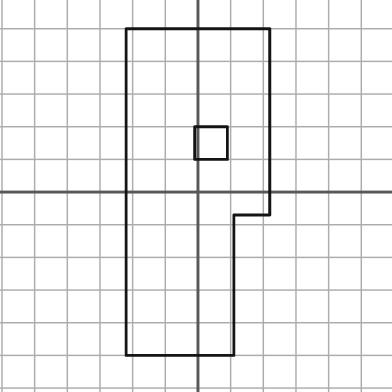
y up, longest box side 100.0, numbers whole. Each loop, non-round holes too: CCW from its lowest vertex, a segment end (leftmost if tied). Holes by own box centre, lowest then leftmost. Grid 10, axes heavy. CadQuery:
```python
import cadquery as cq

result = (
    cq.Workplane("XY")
    .moveTo(-22.0, -50.0)
    .lineTo(11.0, -50.0)
    .lineTo(11.0, -7.0)
    .lineTo(22.0, -7.0)
    .lineTo(22.0, 50.0)
    .lineTo(-22.0, 50.0)
    .close()
    .moveTo(-1.0, 10.0)
    .lineTo(9.0, 10.0)
    .lineTo(9.0, 20.0)
    .lineTo(-1.0, 20.0)
    .close()
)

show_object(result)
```